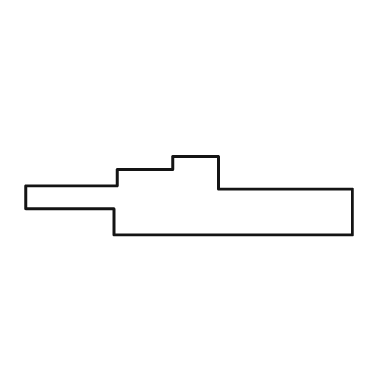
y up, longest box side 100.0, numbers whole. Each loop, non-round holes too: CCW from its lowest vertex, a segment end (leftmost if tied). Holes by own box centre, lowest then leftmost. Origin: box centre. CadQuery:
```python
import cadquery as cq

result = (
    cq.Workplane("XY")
    .moveTo(-23.0, -12.0)
    .lineTo(50.0, -12.0)
    .lineTo(50.0, 2.0)
    .lineTo(9.0, 2.0)
    .lineTo(9.0, 12.0)
    .lineTo(-5.0, 12.0)
    .lineTo(-5.0, 8.0)
    .lineTo(-22.0, 8.0)
    .lineTo(-22.0, 3.0)
    .lineTo(-50.0, 3.0)
    .lineTo(-50.0, -4.0)
    .lineTo(-23.0, -4.0)
    .close()
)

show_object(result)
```